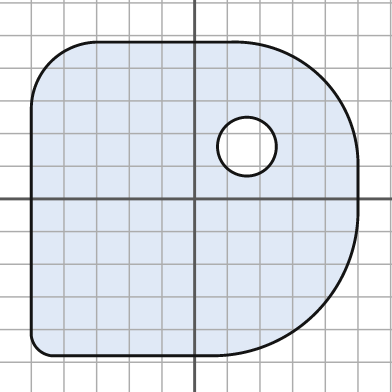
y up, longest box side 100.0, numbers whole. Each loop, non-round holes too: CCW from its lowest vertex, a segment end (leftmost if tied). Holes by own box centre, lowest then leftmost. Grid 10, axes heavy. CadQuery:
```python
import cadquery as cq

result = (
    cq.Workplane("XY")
    .moveTo(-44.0, -48.0)
    .lineTo(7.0, -48.0)
    .threePointArc((37.0, -35.0), (50.0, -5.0))
    .lineTo(50.0, 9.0)
    .threePointArc((39.0, 37.0), (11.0, 48.0))
    .lineTo(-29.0, 48.0)
    .threePointArc((-44.0, 42.0), (-50.0, 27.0))
    .lineTo(-50.0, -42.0)
    .threePointArc((-48.0, -46.0), (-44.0, -48.0))
    .close()
    .moveTo(16.0, 16.0)
    .circle(9.0)
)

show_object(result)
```